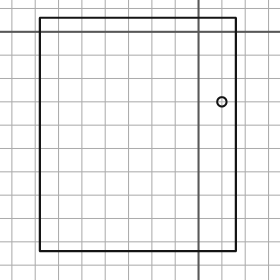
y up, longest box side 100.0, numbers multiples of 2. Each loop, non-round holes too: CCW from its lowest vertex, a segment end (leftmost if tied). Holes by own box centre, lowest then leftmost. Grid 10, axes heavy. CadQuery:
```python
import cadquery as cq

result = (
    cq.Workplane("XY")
    .moveTo(-68.0, -94.0)
    .lineTo(16.0, -94.0)
    .lineTo(16.0, 6.0)
    .lineTo(-68.0, 6.0)
    .close()
    .moveTo(10.0, -30.0)
    .circle(2.0)
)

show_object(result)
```